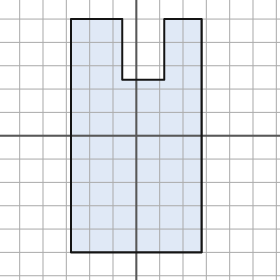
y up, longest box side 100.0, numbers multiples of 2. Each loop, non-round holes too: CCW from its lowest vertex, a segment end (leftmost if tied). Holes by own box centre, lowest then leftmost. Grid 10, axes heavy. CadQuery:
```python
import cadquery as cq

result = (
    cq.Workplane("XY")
    .moveTo(-28.0, -50.0)
    .lineTo(28.0, -50.0)
    .lineTo(28.0, 50.0)
    .lineTo(12.0, 50.0)
    .lineTo(12.0, 24.0)
    .lineTo(-6.0, 24.0)
    .lineTo(-6.0, 50.0)
    .lineTo(-28.0, 50.0)
    .close()
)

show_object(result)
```